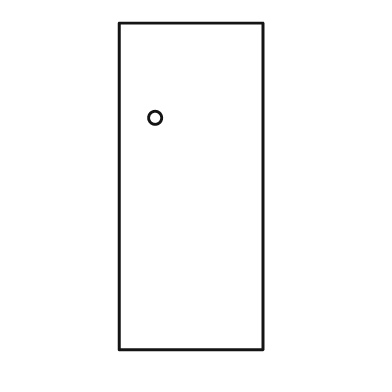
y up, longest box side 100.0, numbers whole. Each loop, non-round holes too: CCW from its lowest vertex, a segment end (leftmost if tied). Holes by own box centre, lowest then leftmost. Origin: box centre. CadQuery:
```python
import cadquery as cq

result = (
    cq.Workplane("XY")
    .moveTo(-22.0, -50.0)
    .lineTo(22.0, -50.0)
    .lineTo(22.0, 50.0)
    .lineTo(-22.0, 50.0)
    .close()
    .moveTo(-11.0, 21.0)
    .circle(2.0)
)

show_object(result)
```